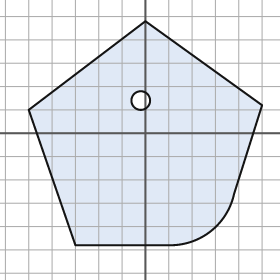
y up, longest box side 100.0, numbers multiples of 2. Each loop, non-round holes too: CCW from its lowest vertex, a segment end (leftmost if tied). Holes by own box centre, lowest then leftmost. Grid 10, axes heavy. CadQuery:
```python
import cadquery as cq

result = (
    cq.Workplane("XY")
    .moveTo(-30.0, -48.0)
    .lineTo(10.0, -48.0)
    .threePointArc((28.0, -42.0), (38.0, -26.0))
    .lineTo(50.0, 12.0)
    .lineTo(0.0, 48.0)
    .lineTo(-50.0, 10.0)
    .close()
    .moveTo(-2.0, 14.0)
    .circle(4.0)
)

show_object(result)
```